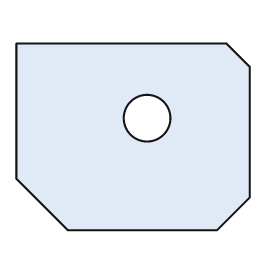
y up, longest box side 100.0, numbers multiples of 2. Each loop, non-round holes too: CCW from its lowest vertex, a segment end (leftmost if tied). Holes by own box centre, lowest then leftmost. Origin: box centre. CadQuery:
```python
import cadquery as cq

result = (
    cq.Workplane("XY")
    .moveTo(-28.0, -40.0)
    .lineTo(36.0, -40.0)
    .lineTo(50.0, -26.0)
    .lineTo(50.0, 30.0)
    .lineTo(40.0, 40.0)
    .lineTo(-50.0, 40.0)
    .lineTo(-50.0, -18.0)
    .close()
    .moveTo(6.0, 8.0)
    .circle(10.0)
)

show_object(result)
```